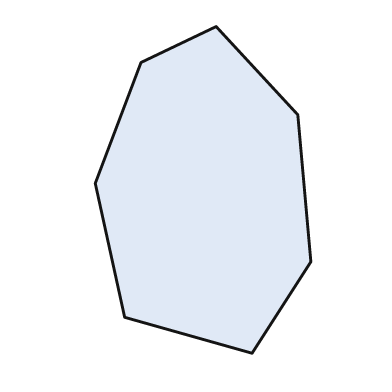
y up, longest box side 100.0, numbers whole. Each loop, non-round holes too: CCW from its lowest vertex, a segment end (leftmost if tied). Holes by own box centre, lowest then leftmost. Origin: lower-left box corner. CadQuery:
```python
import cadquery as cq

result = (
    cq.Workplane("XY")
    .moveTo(48.0, 0.0)
    .lineTo(66.0, 28.0)
    .lineTo(62.0, 73.0)
    .lineTo(37.0, 100.0)
    .lineTo(14.0, 89.0)
    .lineTo(0.0, 52.0)
    .lineTo(9.0, 11.0)
    .close()
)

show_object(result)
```